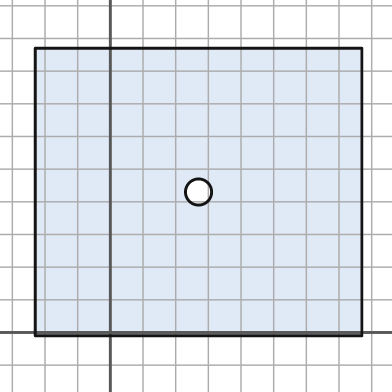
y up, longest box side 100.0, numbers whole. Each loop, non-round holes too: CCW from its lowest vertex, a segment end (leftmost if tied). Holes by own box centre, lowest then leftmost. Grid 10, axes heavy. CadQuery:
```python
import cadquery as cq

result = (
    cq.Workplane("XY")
    .moveTo(-23.0, -1.0)
    .lineTo(77.0, -1.0)
    .lineTo(77.0, 87.0)
    .lineTo(-23.0, 87.0)
    .close()
    .moveTo(27.0, 43.0)
    .circle(4.0)
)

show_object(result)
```